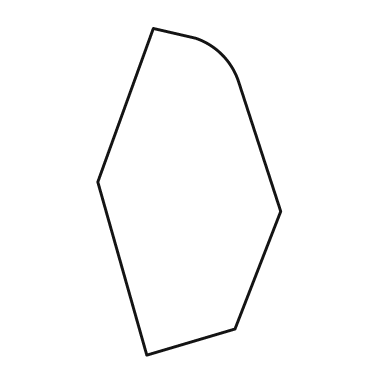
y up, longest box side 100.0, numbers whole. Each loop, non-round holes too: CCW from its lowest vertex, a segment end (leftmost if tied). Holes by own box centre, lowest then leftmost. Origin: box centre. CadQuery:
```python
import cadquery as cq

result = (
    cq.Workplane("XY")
    .moveTo(-13.0, -50.0)
    .lineTo(14.0, -42.0)
    .lineTo(28.0, -6.0)
    .lineTo(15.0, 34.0)
    .threePointArc((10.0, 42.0), (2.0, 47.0))
    .lineTo(-11.0, 50.0)
    .lineTo(-28.0, 3.0)
    .close()
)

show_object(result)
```